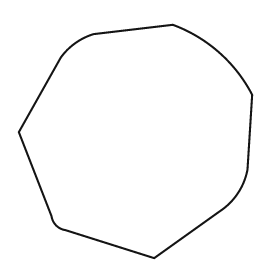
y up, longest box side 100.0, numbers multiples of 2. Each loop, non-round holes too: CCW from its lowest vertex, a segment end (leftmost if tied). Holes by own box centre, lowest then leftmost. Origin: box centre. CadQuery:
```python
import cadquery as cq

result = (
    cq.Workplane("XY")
    .moveTo(8.0, -50.0)
    .lineTo(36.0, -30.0)
    .threePointArc((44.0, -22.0), (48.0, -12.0))
    .lineTo(50.0, 20.0)
    .threePointArc((36.0, 38.0), (16.0, 50.0))
    .lineTo(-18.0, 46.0)
    .threePointArc((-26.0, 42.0), (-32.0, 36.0))
    .lineTo(-50.0, 4.0)
    .lineTo(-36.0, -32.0)
    .threePointArc((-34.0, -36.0), (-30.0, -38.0))
    .close()
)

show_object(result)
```